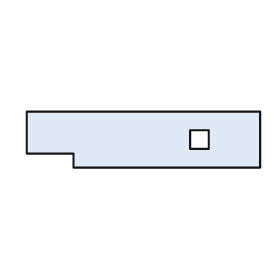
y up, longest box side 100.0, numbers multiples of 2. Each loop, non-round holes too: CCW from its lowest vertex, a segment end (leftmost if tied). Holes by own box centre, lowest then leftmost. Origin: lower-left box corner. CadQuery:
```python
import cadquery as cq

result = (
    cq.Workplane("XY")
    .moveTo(20.0, 0.0)
    .lineTo(100.0, 0.0)
    .lineTo(100.0, 24.0)
    .lineTo(0.0, 24.0)
    .lineTo(0.0, 6.0)
    .lineTo(20.0, 6.0)
    .close()
    .moveTo(70.0, 8.0)
    .lineTo(78.0, 8.0)
    .lineTo(78.0, 16.0)
    .lineTo(70.0, 16.0)
    .close()
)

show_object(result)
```